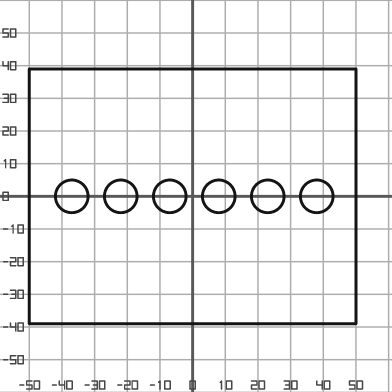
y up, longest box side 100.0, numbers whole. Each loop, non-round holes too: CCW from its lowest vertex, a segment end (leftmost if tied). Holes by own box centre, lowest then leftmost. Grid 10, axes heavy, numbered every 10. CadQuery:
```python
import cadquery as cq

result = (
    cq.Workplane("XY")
    .moveTo(-50.0, -39.0)
    .lineTo(50.0, -39.0)
    .lineTo(50.0, 39.0)
    .lineTo(-50.0, 39.0)
    .close()
    .moveTo(-37.0, 0.0)
    .circle(5.0)
    .moveTo(-22.0, 0.0)
    .circle(5.0)
    .moveTo(-7.0, 0.0)
    .circle(5.0)
    .moveTo(8.0, 0.0)
    .circle(5.0)
    .moveTo(23.0, 0.0)
    .circle(5.0)
    .moveTo(38.0, 0.0)
    .circle(5.0)
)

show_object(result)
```